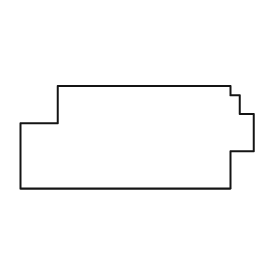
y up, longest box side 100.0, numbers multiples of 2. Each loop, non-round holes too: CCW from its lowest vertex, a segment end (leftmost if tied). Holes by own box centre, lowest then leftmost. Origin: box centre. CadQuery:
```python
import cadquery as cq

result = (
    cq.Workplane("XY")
    .moveTo(-50.0, -22.0)
    .lineTo(40.0, -22.0)
    .lineTo(40.0, -6.0)
    .lineTo(50.0, -6.0)
    .lineTo(50.0, 10.0)
    .lineTo(44.0, 10.0)
    .lineTo(44.0, 18.0)
    .lineTo(40.0, 18.0)
    .lineTo(40.0, 22.0)
    .lineTo(-34.0, 22.0)
    .lineTo(-34.0, 6.0)
    .lineTo(-50.0, 6.0)
    .close()
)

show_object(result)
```